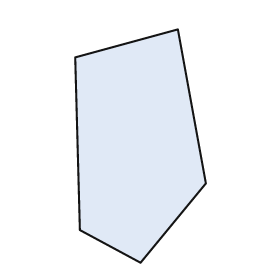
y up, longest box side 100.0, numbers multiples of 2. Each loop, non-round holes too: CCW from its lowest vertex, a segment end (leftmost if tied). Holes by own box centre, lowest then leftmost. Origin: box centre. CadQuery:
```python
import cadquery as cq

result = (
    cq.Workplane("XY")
    .moveTo(0.0, -50.0)
    .lineTo(28.0, -16.0)
    .lineTo(16.0, 50.0)
    .lineTo(-28.0, 38.0)
    .lineTo(-26.0, -36.0)
    .close()
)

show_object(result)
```